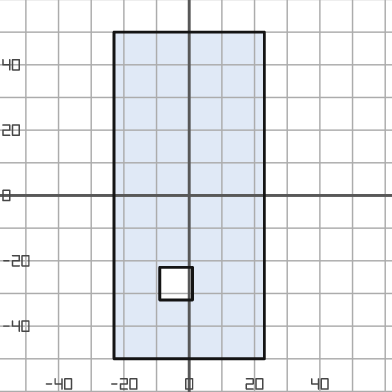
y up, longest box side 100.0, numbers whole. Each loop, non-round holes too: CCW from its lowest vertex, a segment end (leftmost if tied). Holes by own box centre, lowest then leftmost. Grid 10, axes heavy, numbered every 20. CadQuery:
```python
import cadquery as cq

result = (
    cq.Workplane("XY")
    .moveTo(-23.0, -50.0)
    .lineTo(23.0, -50.0)
    .lineTo(23.0, 50.0)
    .lineTo(-23.0, 50.0)
    .close()
    .moveTo(-9.0, -32.0)
    .lineTo(1.0, -32.0)
    .lineTo(1.0, -22.0)
    .lineTo(-9.0, -22.0)
    .close()
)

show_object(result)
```